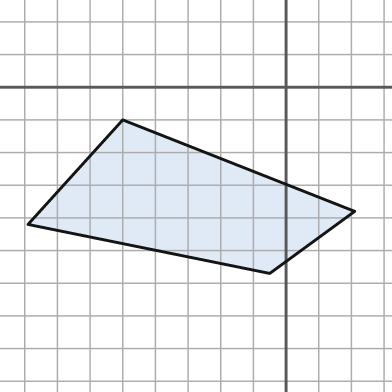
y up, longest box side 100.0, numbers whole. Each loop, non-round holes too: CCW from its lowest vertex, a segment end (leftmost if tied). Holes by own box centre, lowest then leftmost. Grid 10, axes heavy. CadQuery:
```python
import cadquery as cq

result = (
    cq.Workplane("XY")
    .moveTo(-5.0, -57.0)
    .lineTo(21.0, -38.0)
    .lineTo(-50.0, -10.0)
    .lineTo(-79.0, -42.0)
    .close()
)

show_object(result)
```